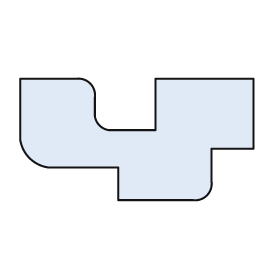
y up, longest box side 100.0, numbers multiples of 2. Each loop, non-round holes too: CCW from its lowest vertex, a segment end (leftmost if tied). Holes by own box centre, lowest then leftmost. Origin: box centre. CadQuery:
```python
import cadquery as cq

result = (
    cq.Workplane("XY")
    .moveTo(-8.0, -26.0)
    .lineTo(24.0, -26.0)
    .threePointArc((30.0, -24.0), (32.0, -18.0))
    .lineTo(32.0, -4.0)
    .lineTo(50.0, -4.0)
    .lineTo(50.0, 26.0)
    .lineTo(8.0, 26.0)
    .lineTo(8.0, 4.0)
    .lineTo(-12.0, 4.0)
    .threePointArc((-16.0, 6.0), (-18.0, 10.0))
    .lineTo(-18.0, 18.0)
    .threePointArc((-20.0, 24.0), (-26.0, 26.0))
    .lineTo(-50.0, 26.0)
    .lineTo(-50.0, 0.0)
    .threePointArc((-46.0, -8.0), (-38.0, -12.0))
    .lineTo(-8.0, -12.0)
    .close()
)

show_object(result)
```